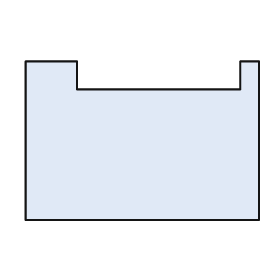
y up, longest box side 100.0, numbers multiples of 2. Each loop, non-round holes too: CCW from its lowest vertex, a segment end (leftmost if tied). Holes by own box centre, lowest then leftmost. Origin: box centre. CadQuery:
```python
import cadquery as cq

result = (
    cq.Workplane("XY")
    .moveTo(-50.0, -34.0)
    .lineTo(50.0, -34.0)
    .lineTo(50.0, 34.0)
    .lineTo(42.0, 34.0)
    .lineTo(42.0, 22.0)
    .lineTo(-28.0, 22.0)
    .lineTo(-28.0, 34.0)
    .lineTo(-50.0, 34.0)
    .close()
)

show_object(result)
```